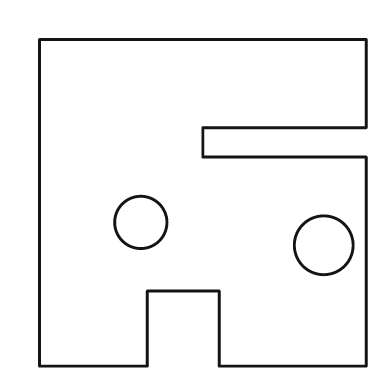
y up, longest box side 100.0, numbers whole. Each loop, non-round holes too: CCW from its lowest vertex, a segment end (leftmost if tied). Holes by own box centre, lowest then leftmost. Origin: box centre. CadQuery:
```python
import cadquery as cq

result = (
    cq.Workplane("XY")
    .moveTo(-50.0, -50.0)
    .lineTo(-17.0, -50.0)
    .lineTo(-17.0, -27.0)
    .lineTo(5.0, -27.0)
    .lineTo(5.0, -50.0)
    .lineTo(50.0, -50.0)
    .lineTo(50.0, 14.0)
    .lineTo(0.0, 14.0)
    .lineTo(0.0, 23.0)
    .lineTo(50.0, 23.0)
    .lineTo(50.0, 50.0)
    .lineTo(-50.0, 50.0)
    .close()
    .moveTo(37.0, -13.0)
    .circle(9.0)
    .moveTo(-19.0, -6.0)
    .circle(8.0)
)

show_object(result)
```